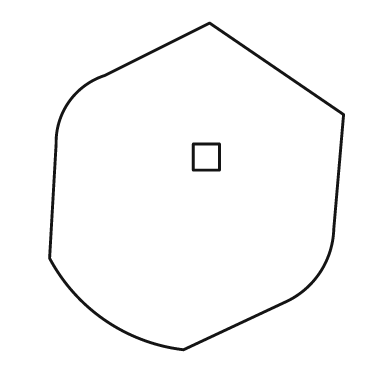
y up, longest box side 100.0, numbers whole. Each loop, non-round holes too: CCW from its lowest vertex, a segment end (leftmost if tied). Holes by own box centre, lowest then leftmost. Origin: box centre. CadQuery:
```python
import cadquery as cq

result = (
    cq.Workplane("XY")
    .moveTo(-4.0, -50.0)
    .lineTo(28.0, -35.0)
    .threePointArc((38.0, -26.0), (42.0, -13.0))
    .lineTo(45.0, 22.0)
    .lineTo(4.0, 50.0)
    .lineTo(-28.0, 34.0)
    .threePointArc((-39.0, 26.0), (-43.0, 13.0))
    .lineTo(-45.0, -22.0)
    .threePointArc((-28.0, -41.0), (-4.0, -50.0))
    .close()
    .moveTo(-1.0, 5.0)
    .lineTo(7.0, 5.0)
    .lineTo(7.0, 13.0)
    .lineTo(-1.0, 13.0)
    .close()
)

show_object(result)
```